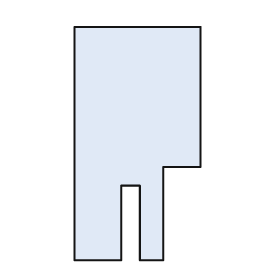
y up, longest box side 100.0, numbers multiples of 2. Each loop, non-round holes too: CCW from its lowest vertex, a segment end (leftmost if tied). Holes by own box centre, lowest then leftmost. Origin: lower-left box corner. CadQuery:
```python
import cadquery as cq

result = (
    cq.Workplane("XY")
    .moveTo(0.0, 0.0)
    .lineTo(20.0, 0.0)
    .lineTo(20.0, 32.0)
    .lineTo(28.0, 32.0)
    .lineTo(28.0, 0.0)
    .lineTo(38.0, 0.0)
    .lineTo(38.0, 40.0)
    .lineTo(54.0, 40.0)
    .lineTo(54.0, 100.0)
    .lineTo(0.0, 100.0)
    .close()
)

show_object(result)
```